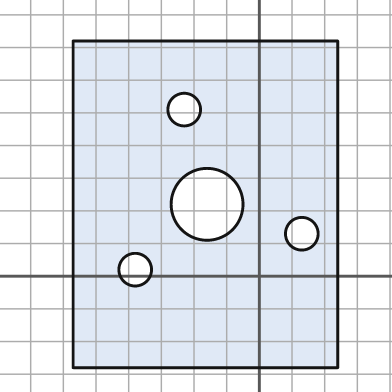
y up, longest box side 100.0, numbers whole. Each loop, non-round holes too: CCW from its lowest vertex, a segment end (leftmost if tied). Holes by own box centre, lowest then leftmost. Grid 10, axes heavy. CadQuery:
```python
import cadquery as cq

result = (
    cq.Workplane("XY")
    .moveTo(-57.0, -28.0)
    .lineTo(24.0, -28.0)
    .lineTo(24.0, 72.0)
    .lineTo(-57.0, 72.0)
    .close()
    .moveTo(-38.0, 2.0)
    .circle(5.0)
    .moveTo(13.0, 13.0)
    .circle(5.0)
    .moveTo(-16.0, 22.0)
    .circle(11.0)
    .moveTo(-23.0, 51.0)
    .circle(5.0)
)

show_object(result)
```